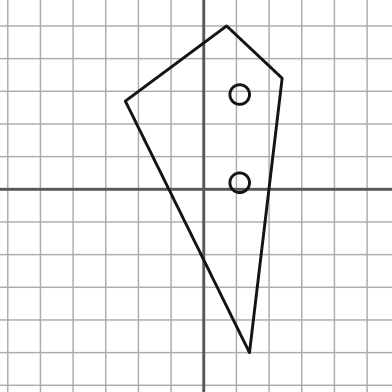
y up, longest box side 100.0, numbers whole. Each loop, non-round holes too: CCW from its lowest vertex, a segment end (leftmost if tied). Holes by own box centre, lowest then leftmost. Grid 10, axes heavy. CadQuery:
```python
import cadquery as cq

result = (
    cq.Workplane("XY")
    .moveTo(14.0, -50.0)
    .lineTo(24.0, 34.0)
    .lineTo(7.0, 50.0)
    .lineTo(-24.0, 27.0)
    .close()
    .moveTo(11.0, 2.0)
    .circle(3.0)
    .moveTo(11.0, 29.0)
    .circle(3.0)
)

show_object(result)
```